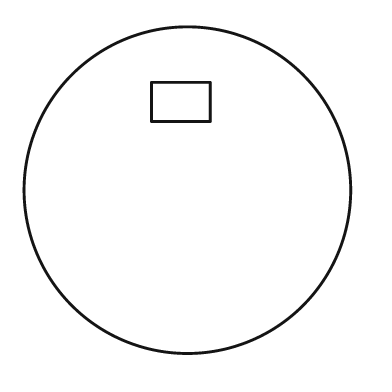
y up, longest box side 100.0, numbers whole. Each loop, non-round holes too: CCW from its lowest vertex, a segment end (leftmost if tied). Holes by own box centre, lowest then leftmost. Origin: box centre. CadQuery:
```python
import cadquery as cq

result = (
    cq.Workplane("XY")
    .moveTo(0.0, 0.0)
    .circle(50.0)
    .moveTo(-11.0, 21.0)
    .lineTo(7.0, 21.0)
    .lineTo(7.0, 33.0)
    .lineTo(-11.0, 33.0)
    .close()
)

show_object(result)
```